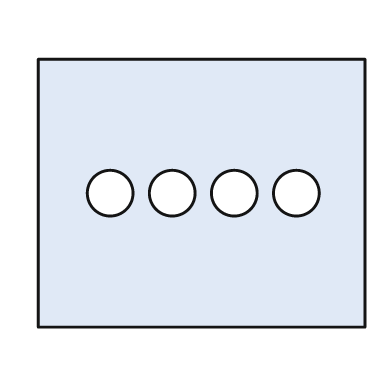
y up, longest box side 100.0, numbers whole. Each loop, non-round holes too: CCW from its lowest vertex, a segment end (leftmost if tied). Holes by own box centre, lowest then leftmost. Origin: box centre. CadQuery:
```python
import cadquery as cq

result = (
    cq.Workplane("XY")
    .moveTo(-50.0, -41.0)
    .lineTo(50.0, -41.0)
    .lineTo(50.0, 41.0)
    .lineTo(-50.0, 41.0)
    .close()
    .moveTo(-28.0, 0.0)
    .circle(7.0)
    .moveTo(-9.0, 0.0)
    .circle(7.0)
    .moveTo(10.0, 0.0)
    .circle(7.0)
    .moveTo(29.0, 0.0)
    .circle(7.0)
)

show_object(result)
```